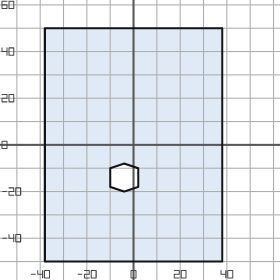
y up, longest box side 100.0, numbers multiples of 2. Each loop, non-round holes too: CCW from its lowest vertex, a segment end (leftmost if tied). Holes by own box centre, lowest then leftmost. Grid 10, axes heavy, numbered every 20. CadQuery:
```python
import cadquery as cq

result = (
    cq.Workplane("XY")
    .moveTo(-38.0, -50.0)
    .lineTo(38.0, -50.0)
    .lineTo(38.0, 50.0)
    .lineTo(-38.0, 50.0)
    .close()
    .moveTo(-4.0, -20.0)
    .lineTo(2.0, -18.0)
    .lineTo(2.0, -10.0)
    .lineTo(-4.0, -8.0)
    .lineTo(-10.0, -10.0)
    .lineTo(-10.0, -18.0)
    .close()
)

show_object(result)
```